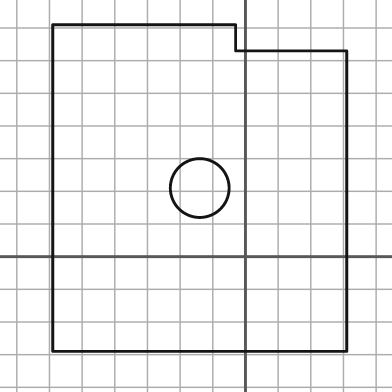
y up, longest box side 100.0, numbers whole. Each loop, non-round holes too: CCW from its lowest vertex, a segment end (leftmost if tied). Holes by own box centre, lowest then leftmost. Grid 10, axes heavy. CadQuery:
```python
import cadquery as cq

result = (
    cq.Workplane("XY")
    .moveTo(-59.0, -29.0)
    .lineTo(31.0, -29.0)
    .lineTo(31.0, 63.0)
    .lineTo(-3.0, 63.0)
    .lineTo(-3.0, 71.0)
    .lineTo(-59.0, 71.0)
    .close()
    .moveTo(-14.0, 21.0)
    .circle(9.0)
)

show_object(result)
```